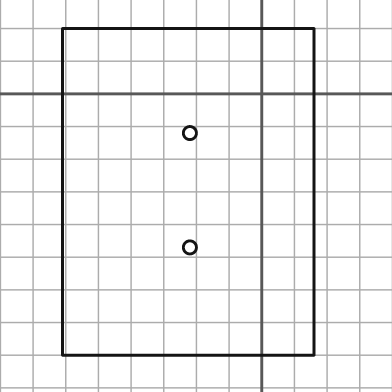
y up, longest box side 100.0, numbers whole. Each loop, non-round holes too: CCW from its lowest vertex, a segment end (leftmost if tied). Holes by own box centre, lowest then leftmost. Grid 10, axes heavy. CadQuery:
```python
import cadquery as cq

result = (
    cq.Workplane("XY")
    .moveTo(-61.0, -80.0)
    .lineTo(16.0, -80.0)
    .lineTo(16.0, 20.0)
    .lineTo(-61.0, 20.0)
    .close()
    .moveTo(-22.0, -47.0)
    .circle(2.0)
    .moveTo(-22.0, -12.0)
    .circle(2.0)
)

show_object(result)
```